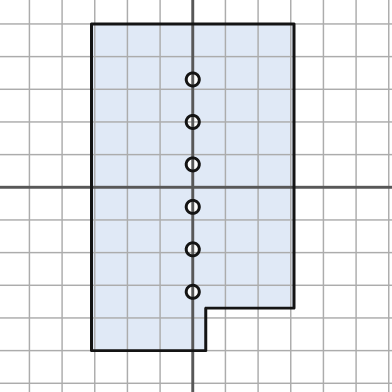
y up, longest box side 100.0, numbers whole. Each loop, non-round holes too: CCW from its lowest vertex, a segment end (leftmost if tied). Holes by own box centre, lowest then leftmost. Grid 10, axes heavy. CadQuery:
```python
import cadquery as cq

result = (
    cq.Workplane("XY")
    .moveTo(-31.0, -50.0)
    .lineTo(4.0, -50.0)
    .lineTo(4.0, -37.0)
    .lineTo(31.0, -37.0)
    .lineTo(31.0, 50.0)
    .lineTo(-31.0, 50.0)
    .close()
    .moveTo(0.0, -32.0)
    .circle(2.0)
    .moveTo(0.0, -19.0)
    .circle(2.0)
    .moveTo(0.0, -6.0)
    .circle(2.0)
    .moveTo(0.0, 7.0)
    .circle(2.0)
    .moveTo(0.0, 20.0)
    .circle(2.0)
    .moveTo(0.0, 33.0)
    .circle(2.0)
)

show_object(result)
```